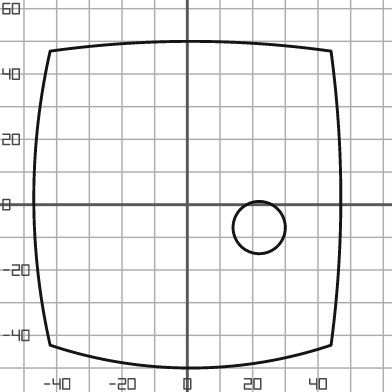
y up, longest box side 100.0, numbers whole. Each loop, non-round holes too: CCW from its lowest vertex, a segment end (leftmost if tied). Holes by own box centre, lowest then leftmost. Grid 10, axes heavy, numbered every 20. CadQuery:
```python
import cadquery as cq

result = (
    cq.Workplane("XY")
    .moveTo(-42.0, -43.0)
    .threePointArc((1.0, -50.0), (44.0, -43.0))
    .threePointArc((47.0, 2.0), (44.0, 47.0))
    .threePointArc((1.0, 50.0), (-42.0, 47.0))
    .threePointArc((-47.0, 2.0), (-42.0, -43.0))
    .close()
    .moveTo(22.0, -7.0)
    .circle(8.0)
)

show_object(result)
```